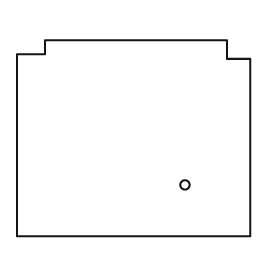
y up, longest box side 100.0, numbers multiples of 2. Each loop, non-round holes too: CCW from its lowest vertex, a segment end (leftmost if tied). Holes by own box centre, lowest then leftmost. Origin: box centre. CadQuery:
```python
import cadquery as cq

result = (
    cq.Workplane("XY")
    .moveTo(-50.0, -42.0)
    .lineTo(50.0, -42.0)
    .lineTo(50.0, 34.0)
    .lineTo(40.0, 34.0)
    .lineTo(40.0, 42.0)
    .lineTo(-38.0, 42.0)
    .lineTo(-38.0, 36.0)
    .lineTo(-50.0, 36.0)
    .close()
    .moveTo(22.0, -20.0)
    .circle(2.0)
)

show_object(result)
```